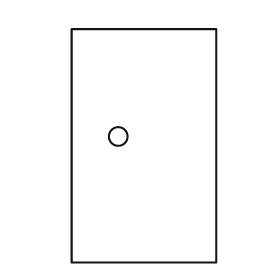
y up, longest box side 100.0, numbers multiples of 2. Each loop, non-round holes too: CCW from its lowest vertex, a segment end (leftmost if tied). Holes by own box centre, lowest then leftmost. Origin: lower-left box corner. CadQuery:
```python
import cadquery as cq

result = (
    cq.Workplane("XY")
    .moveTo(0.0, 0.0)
    .lineTo(62.0, 0.0)
    .lineTo(62.0, 100.0)
    .lineTo(0.0, 100.0)
    .close()
    .moveTo(20.0, 54.0)
    .circle(4.0)
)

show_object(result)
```